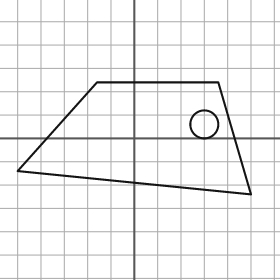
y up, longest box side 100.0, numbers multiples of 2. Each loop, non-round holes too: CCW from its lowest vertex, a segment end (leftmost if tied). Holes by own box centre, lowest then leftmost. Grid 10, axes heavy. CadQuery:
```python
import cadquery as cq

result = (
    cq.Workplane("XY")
    .moveTo(50.0, -24.0)
    .lineTo(36.0, 24.0)
    .lineTo(-16.0, 24.0)
    .lineTo(-50.0, -14.0)
    .close()
    .moveTo(30.0, 6.0)
    .circle(6.0)
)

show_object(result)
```